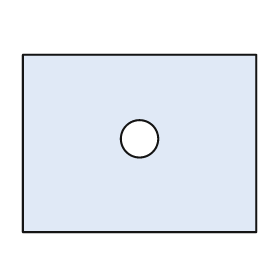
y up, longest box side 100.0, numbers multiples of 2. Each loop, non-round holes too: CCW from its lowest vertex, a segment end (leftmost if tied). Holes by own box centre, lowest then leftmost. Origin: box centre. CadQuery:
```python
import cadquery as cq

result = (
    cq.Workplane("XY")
    .moveTo(-50.0, -38.0)
    .lineTo(50.0, -38.0)
    .lineTo(50.0, 38.0)
    .lineTo(-50.0, 38.0)
    .close()
    .moveTo(0.0, 2.0)
    .circle(8.0)
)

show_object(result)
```